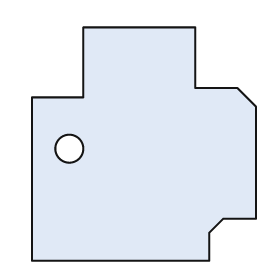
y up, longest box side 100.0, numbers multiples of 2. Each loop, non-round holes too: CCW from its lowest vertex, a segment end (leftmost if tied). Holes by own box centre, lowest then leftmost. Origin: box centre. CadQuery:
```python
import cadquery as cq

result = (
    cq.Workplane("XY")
    .moveTo(-48.0, -50.0)
    .lineTo(28.0, -50.0)
    .lineTo(28.0, -38.0)
    .lineTo(34.0, -32.0)
    .lineTo(48.0, -32.0)
    .lineTo(48.0, 16.0)
    .lineTo(40.0, 24.0)
    .lineTo(22.0, 24.0)
    .lineTo(22.0, 50.0)
    .lineTo(-26.0, 50.0)
    .lineTo(-26.0, 20.0)
    .lineTo(-48.0, 20.0)
    .close()
    .moveTo(-32.0, -2.0)
    .circle(6.0)
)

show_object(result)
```